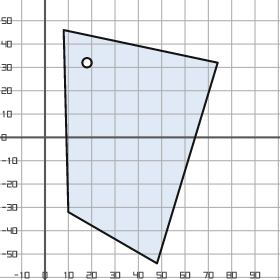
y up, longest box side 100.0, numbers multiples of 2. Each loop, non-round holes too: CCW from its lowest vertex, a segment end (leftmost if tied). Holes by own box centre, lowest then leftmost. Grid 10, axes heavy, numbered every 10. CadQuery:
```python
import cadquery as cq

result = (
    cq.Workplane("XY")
    .moveTo(48.0, -54.0)
    .lineTo(74.0, 32.0)
    .lineTo(8.0, 46.0)
    .lineTo(10.0, -32.0)
    .close()
    .moveTo(18.0, 32.0)
    .circle(2.0)
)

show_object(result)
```